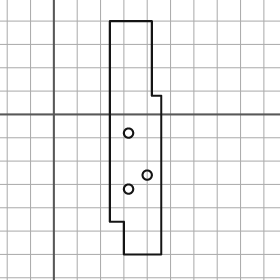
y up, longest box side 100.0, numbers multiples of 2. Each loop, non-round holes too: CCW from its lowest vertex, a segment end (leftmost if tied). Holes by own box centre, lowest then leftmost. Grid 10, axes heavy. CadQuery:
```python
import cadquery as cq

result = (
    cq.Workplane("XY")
    .moveTo(30.0, -60.0)
    .lineTo(46.0, -60.0)
    .lineTo(46.0, 8.0)
    .lineTo(42.0, 8.0)
    .lineTo(42.0, 40.0)
    .lineTo(24.0, 40.0)
    .lineTo(24.0, -46.0)
    .lineTo(30.0, -46.0)
    .close()
    .moveTo(32.0, -32.0)
    .circle(2.0)
    .moveTo(40.0, -26.0)
    .circle(2.0)
    .moveTo(32.0, -8.0)
    .circle(2.0)
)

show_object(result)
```